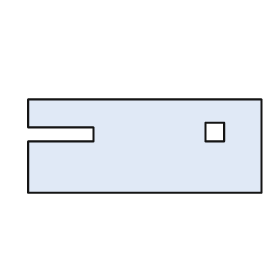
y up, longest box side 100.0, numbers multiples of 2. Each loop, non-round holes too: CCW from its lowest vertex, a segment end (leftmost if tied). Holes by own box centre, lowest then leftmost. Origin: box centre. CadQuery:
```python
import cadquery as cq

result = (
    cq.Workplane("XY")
    .moveTo(-50.0, -20.0)
    .lineTo(50.0, -20.0)
    .lineTo(50.0, 20.0)
    .lineTo(-50.0, 20.0)
    .lineTo(-50.0, 8.0)
    .lineTo(-22.0, 8.0)
    .lineTo(-22.0, 2.0)
    .lineTo(-50.0, 2.0)
    .close()
    .moveTo(26.0, 2.0)
    .lineTo(34.0, 2.0)
    .lineTo(34.0, 10.0)
    .lineTo(26.0, 10.0)
    .close()
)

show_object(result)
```